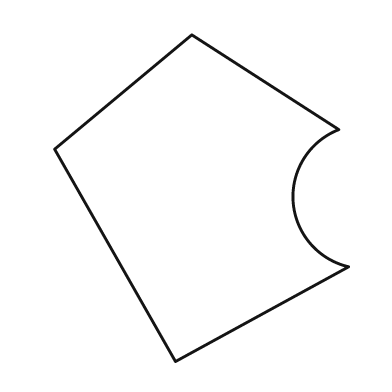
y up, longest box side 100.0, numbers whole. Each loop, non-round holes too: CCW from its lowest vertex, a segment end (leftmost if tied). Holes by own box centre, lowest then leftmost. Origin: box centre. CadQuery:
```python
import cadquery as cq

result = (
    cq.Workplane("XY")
    .moveTo(-8.0, -50.0)
    .lineTo(45.0, -21.0)
    .threePointArc((28.0, -1.0), (42.0, 21.0))
    .lineTo(-3.0, 50.0)
    .lineTo(-45.0, 15.0)
    .close()
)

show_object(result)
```